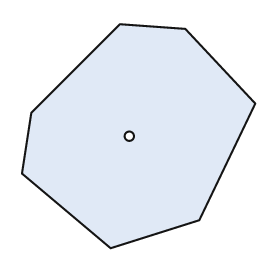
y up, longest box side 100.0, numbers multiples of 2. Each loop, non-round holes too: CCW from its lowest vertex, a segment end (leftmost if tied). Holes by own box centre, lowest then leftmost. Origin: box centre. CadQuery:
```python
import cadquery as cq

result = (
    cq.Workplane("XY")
    .moveTo(-12.0, -48.0)
    .lineTo(26.0, -36.0)
    .lineTo(50.0, 14.0)
    .lineTo(20.0, 46.0)
    .lineTo(-8.0, 48.0)
    .lineTo(-46.0, 10.0)
    .lineTo(-50.0, -16.0)
    .close()
    .moveTo(-4.0, 0.0)
    .circle(2.0)
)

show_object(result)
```